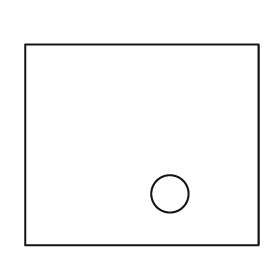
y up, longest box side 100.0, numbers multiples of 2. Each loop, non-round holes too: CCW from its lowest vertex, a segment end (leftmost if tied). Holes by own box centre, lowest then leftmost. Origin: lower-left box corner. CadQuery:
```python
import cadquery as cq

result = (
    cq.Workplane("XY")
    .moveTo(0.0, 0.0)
    .lineTo(100.0, 0.0)
    .lineTo(100.0, 86.0)
    .lineTo(0.0, 86.0)
    .close()
    .moveTo(62.0, 22.0)
    .circle(8.0)
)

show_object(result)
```